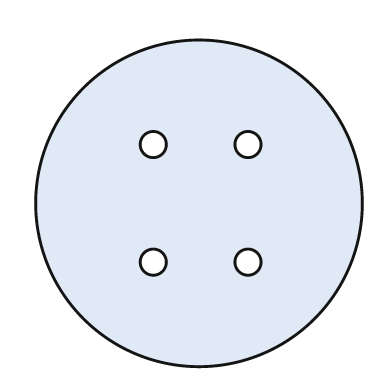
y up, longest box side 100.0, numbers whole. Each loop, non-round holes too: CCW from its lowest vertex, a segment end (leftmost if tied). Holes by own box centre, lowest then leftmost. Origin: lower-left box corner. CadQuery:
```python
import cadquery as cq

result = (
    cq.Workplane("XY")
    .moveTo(50.0, 50.0)
    .circle(50.0)
    .moveTo(36.0, 32.0)
    .circle(4.0)
    .moveTo(65.0, 32.0)
    .circle(4.0)
    .moveTo(36.0, 68.0)
    .circle(4.0)
    .moveTo(65.0, 68.0)
    .circle(4.0)
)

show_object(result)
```